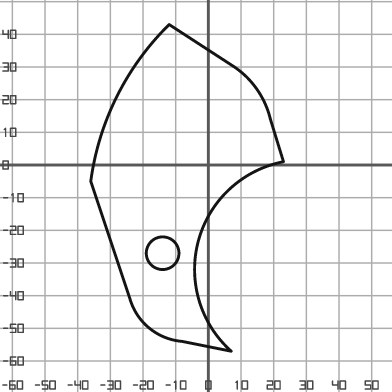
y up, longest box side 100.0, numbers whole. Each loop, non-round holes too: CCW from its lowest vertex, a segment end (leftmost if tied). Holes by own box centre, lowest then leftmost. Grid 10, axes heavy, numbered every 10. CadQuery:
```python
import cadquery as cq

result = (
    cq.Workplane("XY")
    .moveTo(7.0, -57.0)
    .threePointArc((-3.0, -23.0), (23.0, 1.0))
    .lineTo(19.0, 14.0)
    .threePointArc((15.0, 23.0), (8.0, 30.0))
    .lineTo(-12.0, 43.0)
    .threePointArc((-28.0, 21.0), (-36.0, -5.0))
    .lineTo(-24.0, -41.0)
    .threePointArc((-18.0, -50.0), (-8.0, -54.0))
    .close()
    .moveTo(-14.0, -27.0)
    .circle(5.0)
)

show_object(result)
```